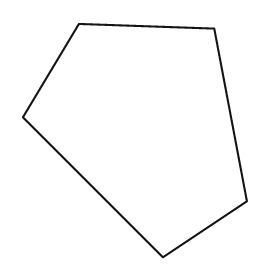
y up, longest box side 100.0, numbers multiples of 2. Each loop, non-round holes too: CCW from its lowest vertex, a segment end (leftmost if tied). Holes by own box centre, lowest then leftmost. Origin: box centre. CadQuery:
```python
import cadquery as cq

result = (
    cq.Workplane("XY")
    .moveTo(12.0, -50.0)
    .lineTo(48.0, -26.0)
    .lineTo(34.0, 48.0)
    .lineTo(-24.0, 50.0)
    .lineTo(-48.0, 10.0)
    .close()
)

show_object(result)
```